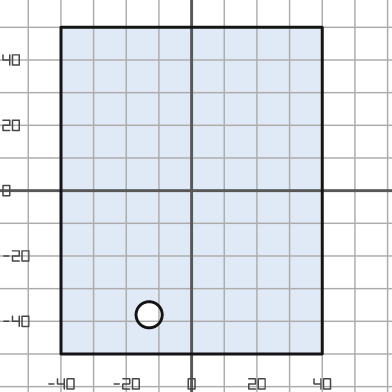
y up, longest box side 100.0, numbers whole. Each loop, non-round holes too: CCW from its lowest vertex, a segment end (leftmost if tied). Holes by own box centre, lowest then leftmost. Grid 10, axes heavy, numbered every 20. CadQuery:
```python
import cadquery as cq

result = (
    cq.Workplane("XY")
    .moveTo(-40.0, -50.0)
    .lineTo(40.0, -50.0)
    .lineTo(40.0, 50.0)
    .lineTo(-40.0, 50.0)
    .close()
    .moveTo(-13.0, -38.0)
    .circle(4.0)
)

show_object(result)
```